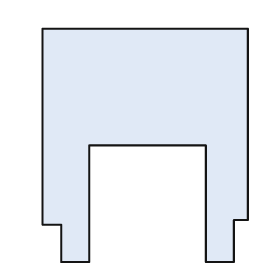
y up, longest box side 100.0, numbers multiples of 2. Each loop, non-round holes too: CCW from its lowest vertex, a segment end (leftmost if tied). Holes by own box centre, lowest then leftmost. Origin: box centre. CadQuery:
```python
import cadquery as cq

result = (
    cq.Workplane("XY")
    .moveTo(-36.0, -50.0)
    .lineTo(-24.0, -50.0)
    .lineTo(-24.0, 0.0)
    .lineTo(26.0, 0.0)
    .lineTo(26.0, -50.0)
    .lineTo(38.0, -50.0)
    .lineTo(38.0, -32.0)
    .lineTo(44.0, -32.0)
    .lineTo(44.0, 50.0)
    .lineTo(-44.0, 50.0)
    .lineTo(-44.0, -34.0)
    .lineTo(-36.0, -34.0)
    .close()
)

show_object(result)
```